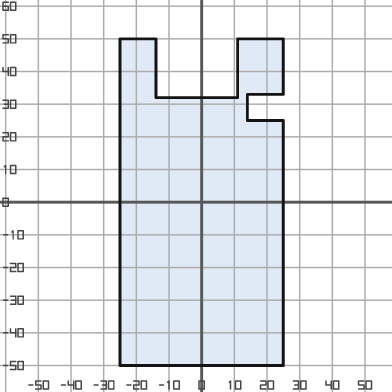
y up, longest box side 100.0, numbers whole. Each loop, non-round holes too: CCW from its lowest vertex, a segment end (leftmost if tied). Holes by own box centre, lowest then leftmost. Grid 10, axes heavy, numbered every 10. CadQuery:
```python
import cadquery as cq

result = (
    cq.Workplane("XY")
    .moveTo(-25.0, -50.0)
    .lineTo(25.0, -50.0)
    .lineTo(25.0, 25.0)
    .lineTo(14.0, 25.0)
    .lineTo(14.0, 33.0)
    .lineTo(25.0, 33.0)
    .lineTo(25.0, 50.0)
    .lineTo(11.0, 50.0)
    .lineTo(11.0, 32.0)
    .lineTo(-14.0, 32.0)
    .lineTo(-14.0, 50.0)
    .lineTo(-25.0, 50.0)
    .close()
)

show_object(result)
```